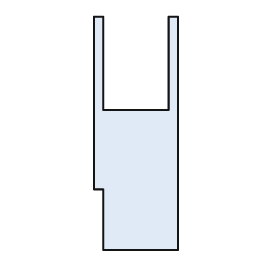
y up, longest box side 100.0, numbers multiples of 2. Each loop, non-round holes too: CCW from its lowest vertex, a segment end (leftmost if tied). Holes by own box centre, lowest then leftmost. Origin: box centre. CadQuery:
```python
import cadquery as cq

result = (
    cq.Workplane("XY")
    .moveTo(-14.0, -50.0)
    .lineTo(18.0, -50.0)
    .lineTo(18.0, 50.0)
    .lineTo(14.0, 50.0)
    .lineTo(14.0, 10.0)
    .lineTo(-14.0, 10.0)
    .lineTo(-14.0, 50.0)
    .lineTo(-18.0, 50.0)
    .lineTo(-18.0, -24.0)
    .lineTo(-14.0, -24.0)
    .close()
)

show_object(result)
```